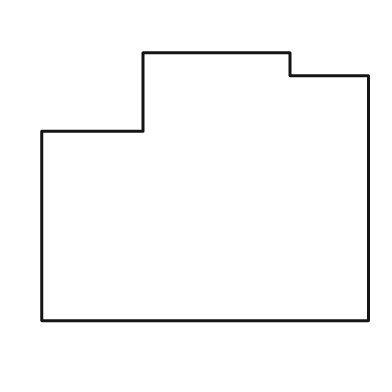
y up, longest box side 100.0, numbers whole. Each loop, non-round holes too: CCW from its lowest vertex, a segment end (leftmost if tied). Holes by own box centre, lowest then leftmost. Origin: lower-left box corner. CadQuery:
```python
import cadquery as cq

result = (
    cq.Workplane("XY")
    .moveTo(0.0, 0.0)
    .lineTo(100.0, 0.0)
    .lineTo(100.0, 75.0)
    .lineTo(76.0, 75.0)
    .lineTo(76.0, 82.0)
    .lineTo(31.0, 82.0)
    .lineTo(31.0, 58.0)
    .lineTo(0.0, 58.0)
    .close()
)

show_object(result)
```